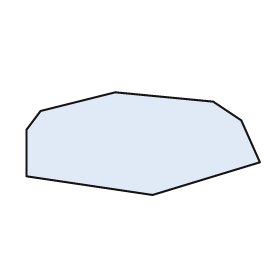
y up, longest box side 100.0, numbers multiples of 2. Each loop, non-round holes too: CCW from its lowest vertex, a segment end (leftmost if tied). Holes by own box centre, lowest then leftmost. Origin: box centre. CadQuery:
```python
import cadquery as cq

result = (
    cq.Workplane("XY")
    .moveTo(4.0, -22.0)
    .lineTo(50.0, -8.0)
    .lineTo(42.0, 10.0)
    .lineTo(30.0, 18.0)
    .lineTo(-12.0, 22.0)
    .lineTo(-44.0, 14.0)
    .lineTo(-50.0, 6.0)
    .lineTo(-50.0, -14.0)
    .close()
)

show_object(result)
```